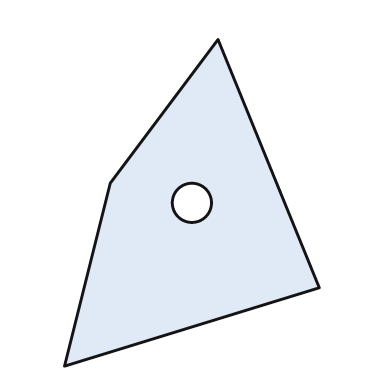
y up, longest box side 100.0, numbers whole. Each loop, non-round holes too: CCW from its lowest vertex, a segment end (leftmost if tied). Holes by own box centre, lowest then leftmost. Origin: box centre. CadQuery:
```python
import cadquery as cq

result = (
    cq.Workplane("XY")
    .moveTo(-39.0, -50.0)
    .lineTo(39.0, -26.0)
    .lineTo(8.0, 50.0)
    .lineTo(-25.0, 6.0)
    .close()
    .moveTo(0.0, 0.0)
    .circle(6.0)
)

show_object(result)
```